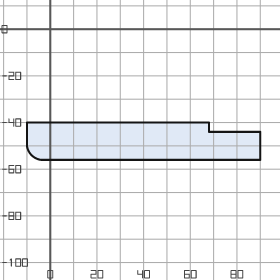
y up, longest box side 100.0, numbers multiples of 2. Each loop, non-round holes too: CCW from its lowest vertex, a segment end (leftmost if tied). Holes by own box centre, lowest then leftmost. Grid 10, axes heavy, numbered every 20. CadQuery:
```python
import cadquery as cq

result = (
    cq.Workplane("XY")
    .moveTo(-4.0, -56.0)
    .lineTo(90.0, -56.0)
    .lineTo(90.0, -44.0)
    .lineTo(68.0, -44.0)
    .lineTo(68.0, -40.0)
    .lineTo(-10.0, -40.0)
    .lineTo(-10.0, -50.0)
    .threePointArc((-8.0, -54.0), (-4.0, -56.0))
    .close()
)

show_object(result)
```